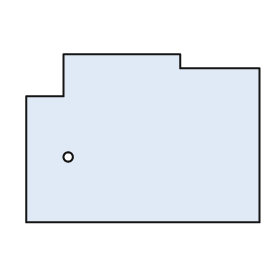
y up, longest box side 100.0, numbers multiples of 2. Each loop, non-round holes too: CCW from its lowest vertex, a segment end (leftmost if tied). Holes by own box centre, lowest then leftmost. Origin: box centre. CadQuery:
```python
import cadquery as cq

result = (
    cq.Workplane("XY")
    .moveTo(-50.0, -36.0)
    .lineTo(50.0, -36.0)
    .lineTo(50.0, 30.0)
    .lineTo(16.0, 30.0)
    .lineTo(16.0, 36.0)
    .lineTo(-34.0, 36.0)
    .lineTo(-34.0, 18.0)
    .lineTo(-50.0, 18.0)
    .close()
    .moveTo(-32.0, -8.0)
    .circle(2.0)
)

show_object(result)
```